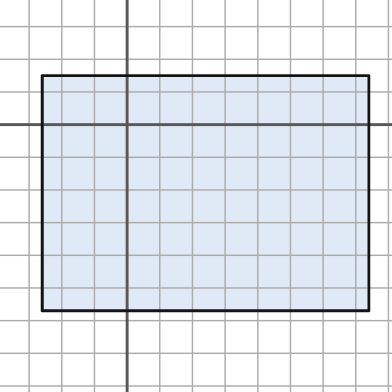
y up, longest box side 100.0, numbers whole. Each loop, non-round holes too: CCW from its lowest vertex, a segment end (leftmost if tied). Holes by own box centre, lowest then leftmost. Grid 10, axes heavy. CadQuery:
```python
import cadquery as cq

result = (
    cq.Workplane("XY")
    .moveTo(-26.0, -57.0)
    .lineTo(74.0, -57.0)
    .lineTo(74.0, 15.0)
    .lineTo(-26.0, 15.0)
    .close()
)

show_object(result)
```